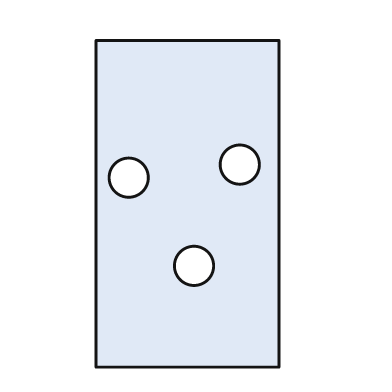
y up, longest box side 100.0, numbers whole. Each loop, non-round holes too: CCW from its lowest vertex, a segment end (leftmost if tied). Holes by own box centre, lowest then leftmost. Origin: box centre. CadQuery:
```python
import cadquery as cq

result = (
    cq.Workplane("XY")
    .moveTo(-28.0, -50.0)
    .lineTo(28.0, -50.0)
    .lineTo(28.0, 50.0)
    .lineTo(-28.0, 50.0)
    .close()
    .moveTo(2.0, -19.0)
    .circle(6.0)
    .moveTo(-18.0, 8.0)
    .circle(6.0)
    .moveTo(16.0, 12.0)
    .circle(6.0)
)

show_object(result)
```